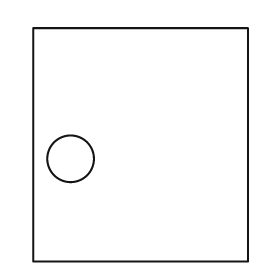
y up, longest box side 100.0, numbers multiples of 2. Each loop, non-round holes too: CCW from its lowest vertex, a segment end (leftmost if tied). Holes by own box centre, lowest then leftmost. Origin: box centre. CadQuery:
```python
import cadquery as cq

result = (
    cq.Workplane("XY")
    .moveTo(-46.0, -50.0)
    .lineTo(46.0, -50.0)
    .lineTo(46.0, 50.0)
    .lineTo(-46.0, 50.0)
    .close()
    .moveTo(-30.0, -6.0)
    .circle(10.0)
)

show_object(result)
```